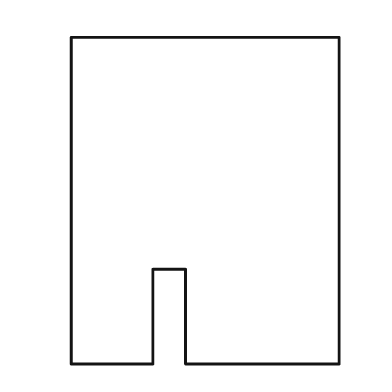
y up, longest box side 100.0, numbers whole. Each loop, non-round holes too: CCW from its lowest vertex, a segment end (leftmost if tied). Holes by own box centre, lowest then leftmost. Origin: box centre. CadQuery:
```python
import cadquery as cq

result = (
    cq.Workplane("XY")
    .moveTo(-41.0, -50.0)
    .lineTo(-16.0, -50.0)
    .lineTo(-16.0, -21.0)
    .lineTo(-6.0, -21.0)
    .lineTo(-6.0, -50.0)
    .lineTo(41.0, -50.0)
    .lineTo(41.0, 50.0)
    .lineTo(-41.0, 50.0)
    .close()
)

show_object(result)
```